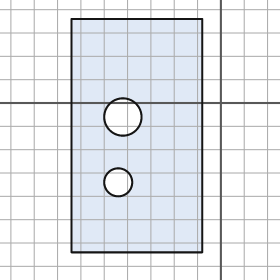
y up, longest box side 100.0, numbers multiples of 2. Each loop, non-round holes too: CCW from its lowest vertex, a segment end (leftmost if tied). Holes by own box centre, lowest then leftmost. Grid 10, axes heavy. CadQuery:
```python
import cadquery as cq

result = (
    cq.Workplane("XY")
    .moveTo(-64.0, -64.0)
    .lineTo(-8.0, -64.0)
    .lineTo(-8.0, 36.0)
    .lineTo(-64.0, 36.0)
    .close()
    .moveTo(-44.0, -34.0)
    .circle(6.0)
    .moveTo(-42.0, -6.0)
    .circle(8.0)
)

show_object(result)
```